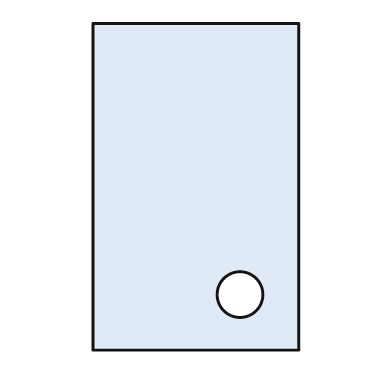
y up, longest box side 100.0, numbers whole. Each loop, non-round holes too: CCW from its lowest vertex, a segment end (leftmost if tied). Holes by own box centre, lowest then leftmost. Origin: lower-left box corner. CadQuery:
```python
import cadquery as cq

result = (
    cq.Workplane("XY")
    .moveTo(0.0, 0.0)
    .lineTo(63.0, 0.0)
    .lineTo(63.0, 100.0)
    .lineTo(0.0, 100.0)
    .close()
    .moveTo(45.0, 17.0)
    .circle(7.0)
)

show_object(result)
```